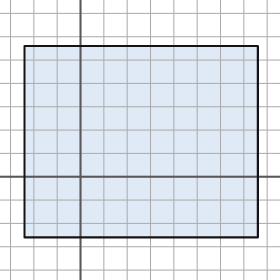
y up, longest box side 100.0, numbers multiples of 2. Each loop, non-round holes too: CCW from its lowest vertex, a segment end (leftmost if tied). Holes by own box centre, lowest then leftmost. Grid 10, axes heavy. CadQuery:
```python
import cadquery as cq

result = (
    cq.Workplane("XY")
    .moveTo(-24.0, -26.0)
    .lineTo(76.0, -26.0)
    .lineTo(76.0, 56.0)
    .lineTo(-24.0, 56.0)
    .close()
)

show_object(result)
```